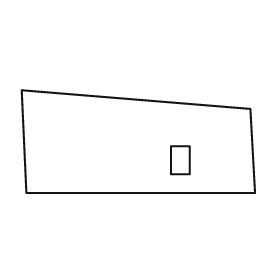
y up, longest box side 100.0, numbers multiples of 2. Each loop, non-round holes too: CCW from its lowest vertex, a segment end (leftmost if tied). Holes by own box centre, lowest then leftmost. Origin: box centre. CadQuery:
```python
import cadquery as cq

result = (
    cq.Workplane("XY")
    .moveTo(-48.0, -22.0)
    .lineTo(50.0, -22.0)
    .lineTo(48.0, 14.0)
    .lineTo(-50.0, 22.0)
    .close()
    .moveTo(14.0, -14.0)
    .lineTo(22.0, -14.0)
    .lineTo(22.0, -2.0)
    .lineTo(14.0, -2.0)
    .close()
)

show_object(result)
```